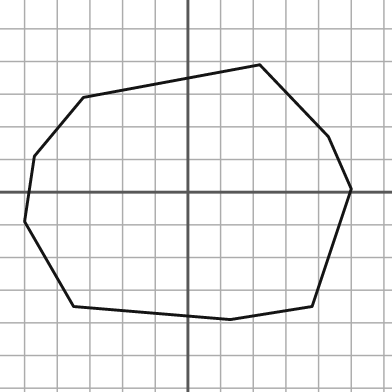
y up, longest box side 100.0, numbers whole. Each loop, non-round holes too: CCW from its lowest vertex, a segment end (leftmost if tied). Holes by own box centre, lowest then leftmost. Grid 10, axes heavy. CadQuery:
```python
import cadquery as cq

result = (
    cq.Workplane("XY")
    .moveTo(13.0, -39.0)
    .lineTo(38.0, -35.0)
    .lineTo(50.0, 1.0)
    .lineTo(43.0, 17.0)
    .lineTo(22.0, 39.0)
    .lineTo(-32.0, 29.0)
    .lineTo(-47.0, 11.0)
    .lineTo(-50.0, -9.0)
    .lineTo(-35.0, -35.0)
    .close()
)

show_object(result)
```